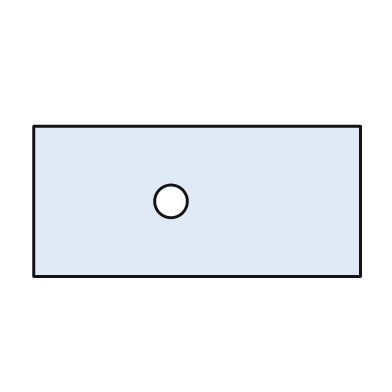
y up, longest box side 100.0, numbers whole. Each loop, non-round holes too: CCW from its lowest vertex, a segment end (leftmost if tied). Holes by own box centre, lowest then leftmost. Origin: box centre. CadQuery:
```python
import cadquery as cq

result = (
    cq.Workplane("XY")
    .moveTo(-50.0, -23.0)
    .lineTo(50.0, -23.0)
    .lineTo(50.0, 23.0)
    .lineTo(-50.0, 23.0)
    .close()
    .moveTo(-8.0, 0.0)
    .circle(5.0)
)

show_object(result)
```